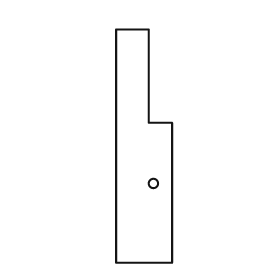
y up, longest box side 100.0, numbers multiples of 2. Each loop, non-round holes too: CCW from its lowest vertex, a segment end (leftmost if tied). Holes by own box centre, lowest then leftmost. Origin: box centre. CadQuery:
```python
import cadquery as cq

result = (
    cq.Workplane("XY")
    .moveTo(-12.0, -50.0)
    .lineTo(12.0, -50.0)
    .lineTo(12.0, 10.0)
    .lineTo(2.0, 10.0)
    .lineTo(2.0, 50.0)
    .lineTo(-12.0, 50.0)
    .close()
    .moveTo(4.0, -16.0)
    .circle(2.0)
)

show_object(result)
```